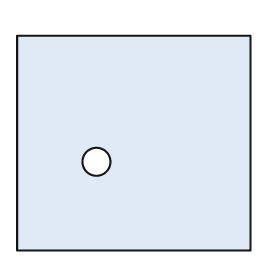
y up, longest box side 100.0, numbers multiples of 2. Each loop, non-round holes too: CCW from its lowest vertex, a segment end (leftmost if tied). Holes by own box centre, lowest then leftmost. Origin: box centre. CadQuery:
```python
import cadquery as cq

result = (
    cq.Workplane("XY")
    .moveTo(-50.0, -46.0)
    .lineTo(50.0, -46.0)
    .lineTo(50.0, 46.0)
    .lineTo(-50.0, 46.0)
    .close()
    .moveTo(-16.0, -8.0)
    .circle(6.0)
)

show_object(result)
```